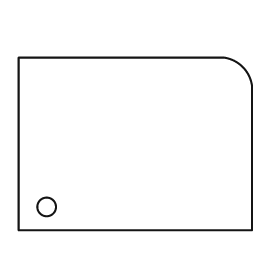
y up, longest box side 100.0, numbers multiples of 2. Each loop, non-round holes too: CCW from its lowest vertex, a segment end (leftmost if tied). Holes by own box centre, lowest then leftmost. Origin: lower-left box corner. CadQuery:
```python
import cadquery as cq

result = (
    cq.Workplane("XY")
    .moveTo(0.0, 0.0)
    .lineTo(100.0, 0.0)
    .lineTo(100.0, 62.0)
    .threePointArc((96.0, 70.0), (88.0, 74.0))
    .lineTo(0.0, 74.0)
    .close()
    .moveTo(12.0, 10.0)
    .circle(4.0)
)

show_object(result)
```